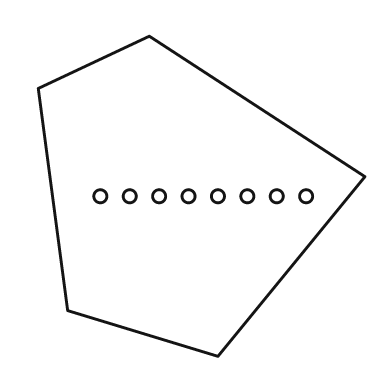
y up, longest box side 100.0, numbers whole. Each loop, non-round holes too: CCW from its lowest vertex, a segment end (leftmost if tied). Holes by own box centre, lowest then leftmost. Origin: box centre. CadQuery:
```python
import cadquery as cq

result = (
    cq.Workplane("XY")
    .moveTo(5.0, -49.0)
    .lineTo(50.0, 6.0)
    .lineTo(-16.0, 49.0)
    .lineTo(-50.0, 33.0)
    .lineTo(-41.0, -35.0)
    .close()
    .moveTo(-31.0, 0.0)
    .circle(2.0)
    .moveTo(-22.0, 0.0)
    .circle(2.0)
    .moveTo(-13.0, 0.0)
    .circle(2.0)
    .moveTo(-4.0, 0.0)
    .circle(2.0)
    .moveTo(5.0, 0.0)
    .circle(2.0)
    .moveTo(14.0, 0.0)
    .circle(2.0)
    .moveTo(23.0, 0.0)
    .circle(2.0)
    .moveTo(32.0, 0.0)
    .circle(2.0)
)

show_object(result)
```